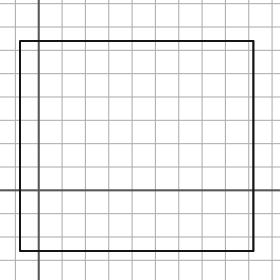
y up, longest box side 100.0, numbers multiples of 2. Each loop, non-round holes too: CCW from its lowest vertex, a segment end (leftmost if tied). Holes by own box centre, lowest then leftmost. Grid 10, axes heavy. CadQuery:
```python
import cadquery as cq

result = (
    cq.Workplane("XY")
    .moveTo(-8.0, -26.0)
    .lineTo(92.0, -26.0)
    .lineTo(92.0, 64.0)
    .lineTo(-8.0, 64.0)
    .close()
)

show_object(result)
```